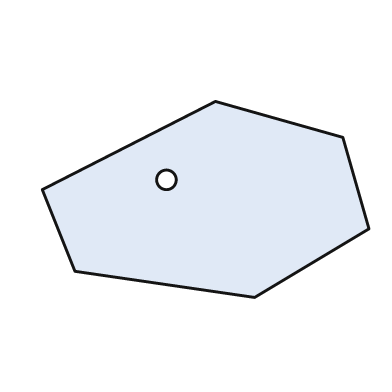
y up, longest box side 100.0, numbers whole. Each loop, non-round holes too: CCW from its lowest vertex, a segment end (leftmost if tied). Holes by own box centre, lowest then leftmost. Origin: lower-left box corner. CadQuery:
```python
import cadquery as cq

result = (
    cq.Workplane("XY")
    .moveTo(65.0, 0.0)
    .lineTo(100.0, 21.0)
    .lineTo(92.0, 49.0)
    .lineTo(53.0, 60.0)
    .lineTo(0.0, 33.0)
    .lineTo(10.0, 8.0)
    .close()
    .moveTo(38.0, 36.0)
    .circle(3.0)
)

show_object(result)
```